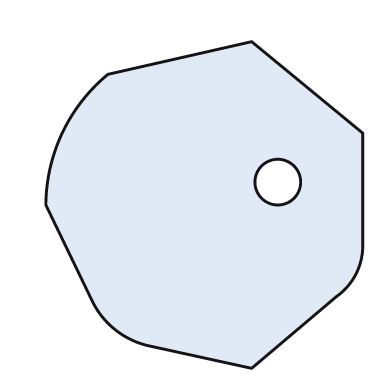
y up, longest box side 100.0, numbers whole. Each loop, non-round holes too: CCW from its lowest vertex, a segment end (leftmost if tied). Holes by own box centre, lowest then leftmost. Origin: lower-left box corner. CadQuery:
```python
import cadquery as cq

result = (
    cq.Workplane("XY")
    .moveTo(63.0, 0.0)
    .lineTo(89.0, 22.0)
    .threePointArc((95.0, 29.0), (97.0, 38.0))
    .lineTo(97.0, 72.0)
    .lineTo(63.0, 100.0)
    .lineTo(19.0, 90.0)
    .threePointArc((5.0, 72.0), (0.0, 50.0))
    .lineTo(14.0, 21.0)
    .threePointArc((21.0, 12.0), (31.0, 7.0))
    .close()
    .moveTo(71.0, 57.0)
    .circle(7.0)
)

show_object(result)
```